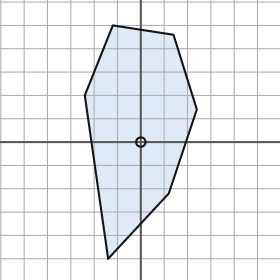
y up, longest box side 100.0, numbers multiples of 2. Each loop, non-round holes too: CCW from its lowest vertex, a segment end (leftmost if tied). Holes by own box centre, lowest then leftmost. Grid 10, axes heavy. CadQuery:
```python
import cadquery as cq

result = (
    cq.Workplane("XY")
    .moveTo(-14.0, -50.0)
    .lineTo(12.0, -22.0)
    .lineTo(24.0, 14.0)
    .lineTo(14.0, 46.0)
    .lineTo(-12.0, 50.0)
    .lineTo(-24.0, 20.0)
    .close()
    .moveTo(0.0, 0.0)
    .circle(2.0)
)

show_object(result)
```